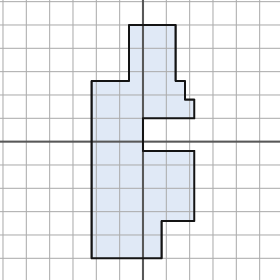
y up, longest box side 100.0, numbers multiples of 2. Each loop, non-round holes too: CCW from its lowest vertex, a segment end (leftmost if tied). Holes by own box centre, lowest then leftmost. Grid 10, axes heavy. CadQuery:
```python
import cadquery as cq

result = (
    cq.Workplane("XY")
    .moveTo(-22.0, -50.0)
    .lineTo(8.0, -50.0)
    .lineTo(8.0, -34.0)
    .lineTo(22.0, -34.0)
    .lineTo(22.0, -4.0)
    .lineTo(0.0, -4.0)
    .lineTo(0.0, 10.0)
    .lineTo(22.0, 10.0)
    .lineTo(22.0, 18.0)
    .lineTo(18.0, 18.0)
    .lineTo(18.0, 26.0)
    .lineTo(14.0, 26.0)
    .lineTo(14.0, 50.0)
    .lineTo(-6.0, 50.0)
    .lineTo(-6.0, 26.0)
    .lineTo(-22.0, 26.0)
    .close()
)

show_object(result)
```